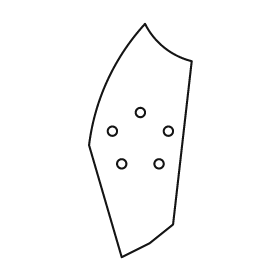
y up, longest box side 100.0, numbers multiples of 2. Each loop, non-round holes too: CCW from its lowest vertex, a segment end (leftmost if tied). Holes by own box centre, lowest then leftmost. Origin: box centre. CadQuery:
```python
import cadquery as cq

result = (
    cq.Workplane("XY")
    .moveTo(-8.0, -50.0)
    .lineTo(4.0, -44.0)
    .lineTo(14.0, -36.0)
    .lineTo(22.0, 34.0)
    .threePointArc((10.0, 40.0), (2.0, 50.0))
    .threePointArc((-14.0, 26.0), (-22.0, -2.0))
    .close()
    .moveTo(-8.0, -10.0)
    .circle(2.0)
    .moveTo(8.0, -10.0)
    .circle(2.0)
    .moveTo(-12.0, 4.0)
    .circle(2.0)
    .moveTo(12.0, 4.0)
    .circle(2.0)
    .moveTo(0.0, 12.0)
    .circle(2.0)
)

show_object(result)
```